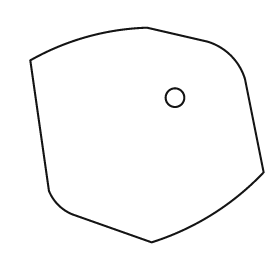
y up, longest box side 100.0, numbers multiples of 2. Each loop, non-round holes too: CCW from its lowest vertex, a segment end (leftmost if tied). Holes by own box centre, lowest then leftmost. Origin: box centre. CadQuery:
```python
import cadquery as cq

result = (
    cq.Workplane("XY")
    .moveTo(2.0, -46.0)
    .threePointArc((28.0, -34.0), (50.0, -16.0))
    .lineTo(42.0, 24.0)
    .threePointArc((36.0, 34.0), (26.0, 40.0))
    .lineTo(0.0, 46.0)
    .threePointArc((-26.0, 42.0), (-50.0, 32.0))
    .lineTo(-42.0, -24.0)
    .threePointArc((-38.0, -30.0), (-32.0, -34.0))
    .close()
    .moveTo(12.0, 16.0)
    .circle(4.0)
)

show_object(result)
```